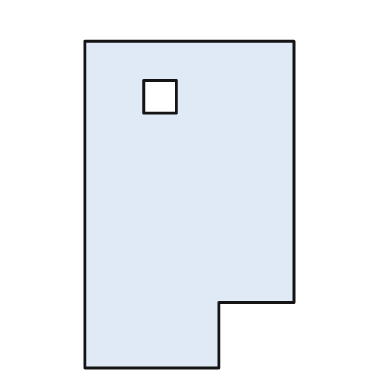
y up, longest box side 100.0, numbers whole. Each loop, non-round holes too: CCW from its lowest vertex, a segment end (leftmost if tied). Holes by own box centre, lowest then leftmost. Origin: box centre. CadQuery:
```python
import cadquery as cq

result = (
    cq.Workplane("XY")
    .moveTo(-32.0, -50.0)
    .lineTo(9.0, -50.0)
    .lineTo(9.0, -30.0)
    .lineTo(32.0, -30.0)
    .lineTo(32.0, 50.0)
    .lineTo(-32.0, 50.0)
    .close()
    .moveTo(-14.0, 28.0)
    .lineTo(-4.0, 28.0)
    .lineTo(-4.0, 38.0)
    .lineTo(-14.0, 38.0)
    .close()
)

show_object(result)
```